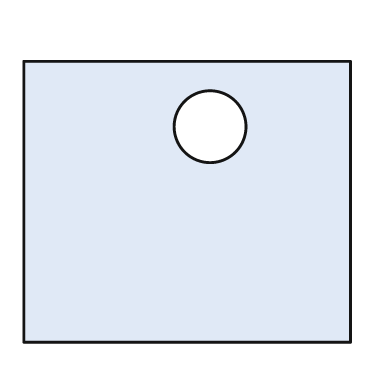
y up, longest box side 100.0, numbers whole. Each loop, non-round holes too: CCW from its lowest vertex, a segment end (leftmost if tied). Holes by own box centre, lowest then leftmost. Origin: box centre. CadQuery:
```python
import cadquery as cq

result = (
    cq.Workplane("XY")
    .moveTo(-50.0, -43.0)
    .lineTo(50.0, -43.0)
    .lineTo(50.0, 43.0)
    .lineTo(-50.0, 43.0)
    .close()
    .moveTo(7.0, 23.0)
    .circle(11.0)
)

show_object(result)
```